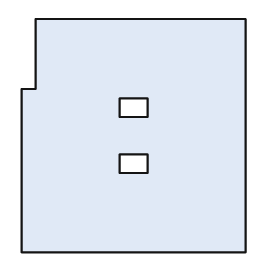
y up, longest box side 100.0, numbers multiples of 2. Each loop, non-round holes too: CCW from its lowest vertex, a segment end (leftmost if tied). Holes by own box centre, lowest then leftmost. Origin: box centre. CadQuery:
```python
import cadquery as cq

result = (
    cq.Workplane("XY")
    .moveTo(-48.0, -50.0)
    .lineTo(48.0, -50.0)
    .lineTo(48.0, 50.0)
    .lineTo(-42.0, 50.0)
    .lineTo(-42.0, 20.0)
    .lineTo(-48.0, 20.0)
    .close()
    .moveTo(-6.0, -16.0)
    .lineTo(6.0, -16.0)
    .lineTo(6.0, -8.0)
    .lineTo(-6.0, -8.0)
    .close()
    .moveTo(-6.0, 8.0)
    .lineTo(6.0, 8.0)
    .lineTo(6.0, 16.0)
    .lineTo(-6.0, 16.0)
    .close()
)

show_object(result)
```